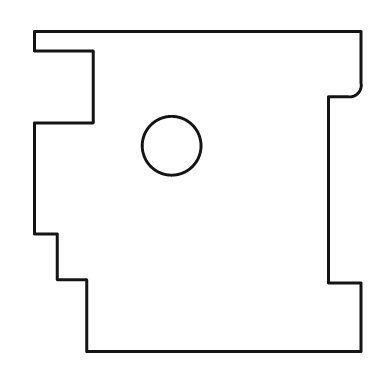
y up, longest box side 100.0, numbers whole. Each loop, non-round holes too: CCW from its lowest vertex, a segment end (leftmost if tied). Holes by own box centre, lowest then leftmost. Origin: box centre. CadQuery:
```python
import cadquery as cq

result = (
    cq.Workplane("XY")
    .moveTo(-34.0, -49.0)
    .lineTo(50.0, -49.0)
    .lineTo(50.0, -28.0)
    .lineTo(40.0, -28.0)
    .lineTo(40.0, 29.0)
    .lineTo(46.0, 29.0)
    .threePointArc((49.0, 30.0), (50.0, 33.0))
    .lineTo(50.0, 49.0)
    .lineTo(-50.0, 49.0)
    .lineTo(-50.0, 43.0)
    .lineTo(-32.0, 43.0)
    .lineTo(-32.0, 21.0)
    .lineTo(-50.0, 21.0)
    .lineTo(-50.0, -13.0)
    .lineTo(-43.0, -13.0)
    .lineTo(-43.0, -27.0)
    .lineTo(-34.0, -27.0)
    .close()
    .moveTo(-8.0, 14.0)
    .circle(9.0)
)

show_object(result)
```